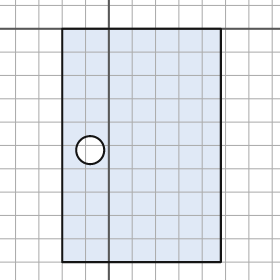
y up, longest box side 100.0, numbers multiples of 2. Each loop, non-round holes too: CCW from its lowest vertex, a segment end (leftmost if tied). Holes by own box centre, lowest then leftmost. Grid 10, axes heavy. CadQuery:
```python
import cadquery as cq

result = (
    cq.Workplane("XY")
    .moveTo(-20.0, -100.0)
    .lineTo(48.0, -100.0)
    .lineTo(48.0, 0.0)
    .lineTo(-20.0, 0.0)
    .close()
    .moveTo(-8.0, -52.0)
    .circle(6.0)
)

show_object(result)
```